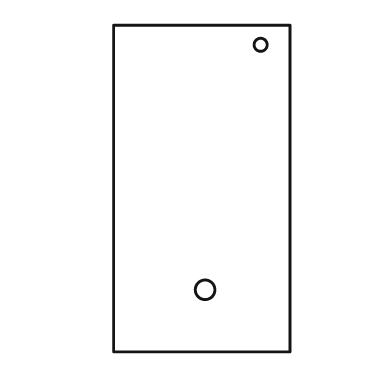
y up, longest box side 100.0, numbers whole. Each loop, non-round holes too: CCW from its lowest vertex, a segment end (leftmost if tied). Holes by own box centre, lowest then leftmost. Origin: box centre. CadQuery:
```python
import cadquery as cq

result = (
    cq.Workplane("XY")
    .moveTo(-27.0, -50.0)
    .lineTo(27.0, -50.0)
    .lineTo(27.0, 50.0)
    .lineTo(-27.0, 50.0)
    .close()
    .moveTo(1.0, -31.0)
    .circle(3.0)
    .moveTo(18.0, 44.0)
    .circle(2.0)
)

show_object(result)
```